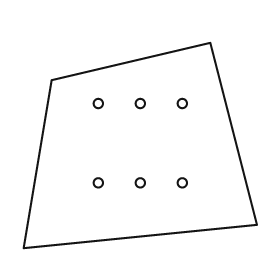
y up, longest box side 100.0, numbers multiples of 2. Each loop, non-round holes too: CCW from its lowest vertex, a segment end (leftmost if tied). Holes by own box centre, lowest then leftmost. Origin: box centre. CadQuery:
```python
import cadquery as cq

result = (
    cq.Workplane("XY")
    .moveTo(-50.0, -44.0)
    .lineTo(50.0, -34.0)
    .lineTo(30.0, 44.0)
    .lineTo(-38.0, 28.0)
    .close()
    .moveTo(-18.0, -16.0)
    .circle(2.0)
    .moveTo(0.0, -16.0)
    .circle(2.0)
    .moveTo(18.0, -16.0)
    .circle(2.0)
    .moveTo(-18.0, 18.0)
    .circle(2.0)
    .moveTo(0.0, 18.0)
    .circle(2.0)
    .moveTo(18.0, 18.0)
    .circle(2.0)
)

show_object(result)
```